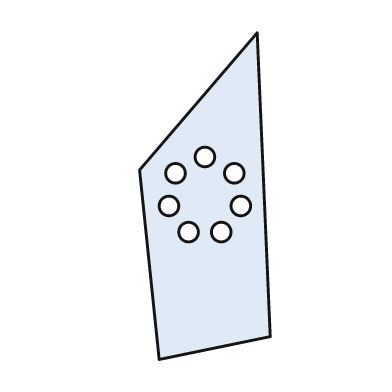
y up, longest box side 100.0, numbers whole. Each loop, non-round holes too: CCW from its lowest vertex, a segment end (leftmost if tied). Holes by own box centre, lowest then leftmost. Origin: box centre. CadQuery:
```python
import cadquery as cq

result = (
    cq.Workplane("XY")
    .moveTo(-14.0, -50.0)
    .lineTo(20.0, -43.0)
    .lineTo(16.0, 50.0)
    .lineTo(-20.0, 8.0)
    .close()
    .moveTo(-5.0, -11.0)
    .circle(3.0)
    .moveTo(5.0, -11.0)
    .circle(3.0)
    .moveTo(-11.0, -3.0)
    .circle(3.0)
    .moveTo(11.0, -3.0)
    .circle(3.0)
    .moveTo(-9.0, 7.0)
    .circle(3.0)
    .moveTo(9.0, 7.0)
    .circle(3.0)
    .moveTo(0.0, 12.0)
    .circle(3.0)
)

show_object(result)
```